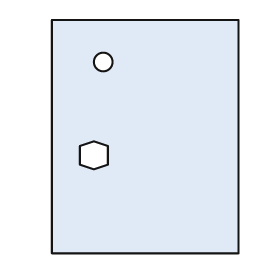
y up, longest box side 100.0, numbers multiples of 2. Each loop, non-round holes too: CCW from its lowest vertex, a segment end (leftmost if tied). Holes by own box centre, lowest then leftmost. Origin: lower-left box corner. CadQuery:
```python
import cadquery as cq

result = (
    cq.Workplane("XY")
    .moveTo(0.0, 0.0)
    .lineTo(80.0, 0.0)
    .lineTo(80.0, 100.0)
    .lineTo(0.0, 100.0)
    .close()
    .moveTo(18.0, 36.0)
    .lineTo(24.0, 38.0)
    .lineTo(24.0, 46.0)
    .lineTo(18.0, 48.0)
    .lineTo(12.0, 46.0)
    .lineTo(12.0, 38.0)
    .close()
    .moveTo(22.0, 82.0)
    .circle(4.0)
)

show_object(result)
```